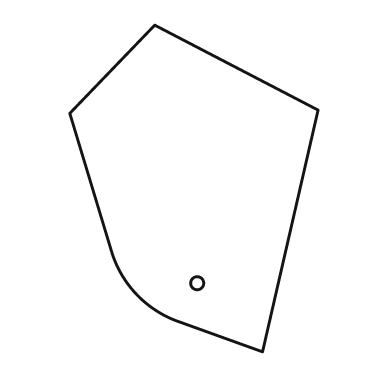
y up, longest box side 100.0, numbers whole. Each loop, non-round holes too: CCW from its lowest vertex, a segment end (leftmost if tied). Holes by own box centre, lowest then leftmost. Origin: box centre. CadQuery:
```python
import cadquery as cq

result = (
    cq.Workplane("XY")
    .moveTo(21.0, -50.0)
    .lineTo(38.0, 24.0)
    .lineTo(-12.0, 50.0)
    .lineTo(-38.0, 23.0)
    .lineTo(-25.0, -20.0)
    .threePointArc((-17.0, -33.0), (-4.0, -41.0))
    .close()
    .moveTo(1.0, -29.0)
    .circle(2.0)
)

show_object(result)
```